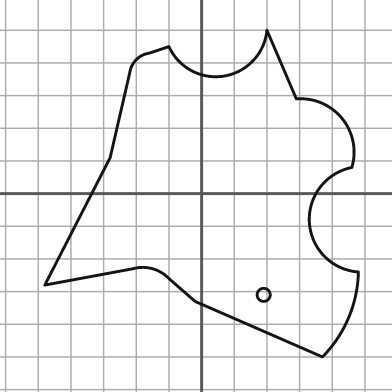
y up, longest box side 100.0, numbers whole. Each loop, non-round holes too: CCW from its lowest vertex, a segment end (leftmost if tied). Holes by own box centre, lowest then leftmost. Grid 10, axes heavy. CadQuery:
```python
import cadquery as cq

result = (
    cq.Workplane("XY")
    .moveTo(37.0, -50.0)
    .threePointArc((45.0, -38.0), (48.0, -24.0))
    .threePointArc((33.0, -9.0), (46.0, 8.0))
    .threePointArc((43.0, 23.0), (29.0, 29.0))
    .lineTo(20.0, 50.0)
    .threePointArc((7.0, 36.0), (-10.0, 45.0))
    .lineTo(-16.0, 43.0)
    .threePointArc((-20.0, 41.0), (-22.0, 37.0))
    .lineTo(-28.0, 11.0)
    .lineTo(-48.0, -28.0)
    .lineTo(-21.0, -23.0)
    .threePointArc((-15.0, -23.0), (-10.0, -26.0))
    .lineTo(-2.0, -33.0)
    .close()
    .moveTo(19.0, -31.0)
    .circle(2.0)
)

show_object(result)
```